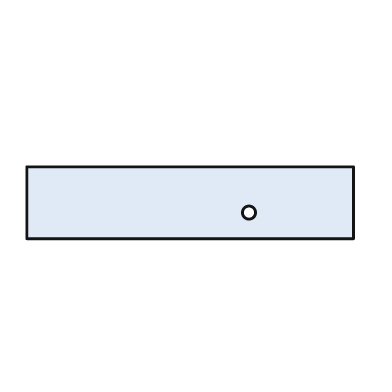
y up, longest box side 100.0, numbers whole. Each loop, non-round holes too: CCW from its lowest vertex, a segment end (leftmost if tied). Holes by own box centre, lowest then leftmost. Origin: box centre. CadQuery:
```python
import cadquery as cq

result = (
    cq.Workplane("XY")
    .moveTo(-50.0, -11.0)
    .lineTo(50.0, -11.0)
    .lineTo(50.0, 11.0)
    .lineTo(-50.0, 11.0)
    .close()
    .moveTo(18.0, -3.0)
    .circle(2.0)
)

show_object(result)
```